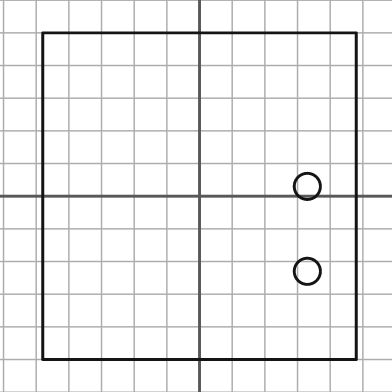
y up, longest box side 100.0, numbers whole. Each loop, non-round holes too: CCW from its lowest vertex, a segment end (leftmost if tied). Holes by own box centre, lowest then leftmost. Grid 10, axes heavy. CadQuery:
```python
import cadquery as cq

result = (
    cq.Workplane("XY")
    .moveTo(-48.0, -50.0)
    .lineTo(48.0, -50.0)
    .lineTo(48.0, 50.0)
    .lineTo(-48.0, 50.0)
    .close()
    .moveTo(33.0, -23.0)
    .circle(4.0)
    .moveTo(33.0, 3.0)
    .circle(4.0)
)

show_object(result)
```